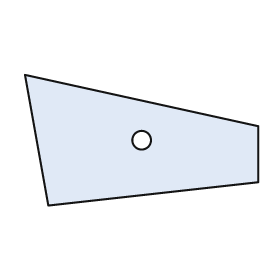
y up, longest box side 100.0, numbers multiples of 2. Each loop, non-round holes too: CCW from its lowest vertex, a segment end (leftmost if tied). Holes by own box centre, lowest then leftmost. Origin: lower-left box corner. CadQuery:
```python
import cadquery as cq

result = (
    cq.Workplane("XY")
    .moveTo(10.0, 0.0)
    .lineTo(100.0, 10.0)
    .lineTo(100.0, 34.0)
    .lineTo(0.0, 56.0)
    .close()
    .moveTo(50.0, 28.0)
    .circle(4.0)
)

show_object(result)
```